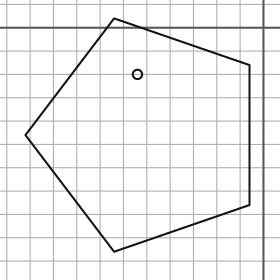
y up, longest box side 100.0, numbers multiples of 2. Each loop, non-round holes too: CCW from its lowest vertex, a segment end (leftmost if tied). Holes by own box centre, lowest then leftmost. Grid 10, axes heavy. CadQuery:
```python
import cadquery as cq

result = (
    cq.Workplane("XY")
    .moveTo(-64.0, -96.0)
    .lineTo(-6.0, -76.0)
    .lineTo(-6.0, -16.0)
    .lineTo(-64.0, 4.0)
    .lineTo(-102.0, -46.0)
    .close()
    .moveTo(-54.0, -20.0)
    .circle(2.0)
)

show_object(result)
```